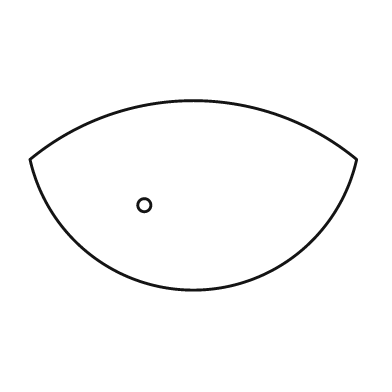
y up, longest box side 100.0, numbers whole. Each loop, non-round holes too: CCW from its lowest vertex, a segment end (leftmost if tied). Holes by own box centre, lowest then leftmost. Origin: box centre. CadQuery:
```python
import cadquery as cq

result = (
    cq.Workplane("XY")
    .moveTo(-50.0, 11.0)
    .threePointArc((0.0, -29.0), (50.0, 11.0))
    .threePointArc((0.0, 29.0), (-50.0, 11.0))
    .close()
    .moveTo(-15.0, -3.0)
    .circle(2.0)
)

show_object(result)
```